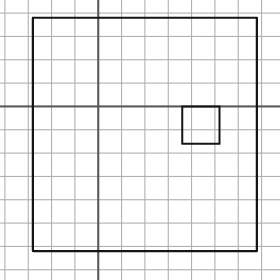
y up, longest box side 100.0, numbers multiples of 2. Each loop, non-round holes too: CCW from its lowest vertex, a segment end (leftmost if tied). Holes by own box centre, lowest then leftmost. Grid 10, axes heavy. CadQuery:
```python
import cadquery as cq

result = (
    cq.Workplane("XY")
    .moveTo(-28.0, -62.0)
    .lineTo(68.0, -62.0)
    .lineTo(68.0, 38.0)
    .lineTo(-28.0, 38.0)
    .close()
    .moveTo(36.0, -16.0)
    .lineTo(52.0, -16.0)
    .lineTo(52.0, 0.0)
    .lineTo(36.0, 0.0)
    .close()
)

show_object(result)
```